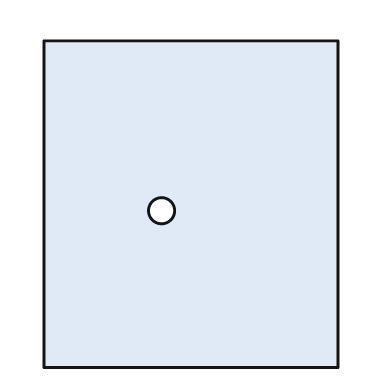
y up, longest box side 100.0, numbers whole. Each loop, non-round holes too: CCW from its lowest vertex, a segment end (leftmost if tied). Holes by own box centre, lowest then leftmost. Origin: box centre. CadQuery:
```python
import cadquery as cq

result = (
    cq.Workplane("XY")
    .moveTo(-45.0, -50.0)
    .lineTo(45.0, -50.0)
    .lineTo(45.0, 50.0)
    .lineTo(-45.0, 50.0)
    .close()
    .moveTo(-9.0, -2.0)
    .circle(4.0)
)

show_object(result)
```